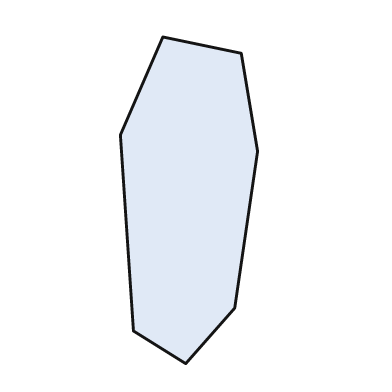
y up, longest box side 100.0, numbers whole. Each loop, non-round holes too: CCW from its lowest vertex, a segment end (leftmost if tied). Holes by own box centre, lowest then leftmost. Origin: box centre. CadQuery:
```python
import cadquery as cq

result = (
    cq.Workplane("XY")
    .moveTo(-1.0, -50.0)
    .lineTo(14.0, -33.0)
    .lineTo(21.0, 15.0)
    .lineTo(16.0, 45.0)
    .lineTo(-8.0, 50.0)
    .lineTo(-21.0, 20.0)
    .lineTo(-17.0, -40.0)
    .close()
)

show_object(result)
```